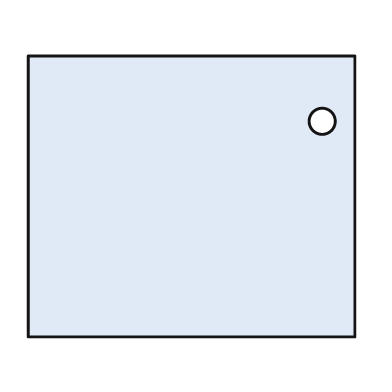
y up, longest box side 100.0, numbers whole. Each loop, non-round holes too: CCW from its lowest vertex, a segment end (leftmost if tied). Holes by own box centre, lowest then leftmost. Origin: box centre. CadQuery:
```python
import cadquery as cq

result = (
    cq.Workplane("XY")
    .moveTo(-50.0, -43.0)
    .lineTo(50.0, -43.0)
    .lineTo(50.0, 43.0)
    .lineTo(-50.0, 43.0)
    .close()
    .moveTo(40.0, 23.0)
    .circle(4.0)
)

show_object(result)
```